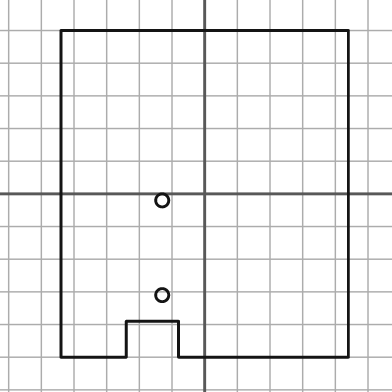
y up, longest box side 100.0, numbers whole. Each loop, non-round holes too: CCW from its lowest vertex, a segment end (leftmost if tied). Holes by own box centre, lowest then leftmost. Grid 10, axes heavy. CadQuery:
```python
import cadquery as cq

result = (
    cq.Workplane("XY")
    .moveTo(-44.0, -50.0)
    .lineTo(-24.0, -50.0)
    .lineTo(-24.0, -39.0)
    .lineTo(-8.0, -39.0)
    .lineTo(-8.0, -50.0)
    .lineTo(44.0, -50.0)
    .lineTo(44.0, 50.0)
    .lineTo(-44.0, 50.0)
    .close()
    .moveTo(-13.0, -31.0)
    .circle(2.0)
    .moveTo(-13.0, -2.0)
    .circle(2.0)
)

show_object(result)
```